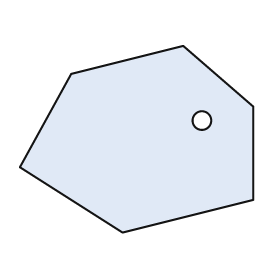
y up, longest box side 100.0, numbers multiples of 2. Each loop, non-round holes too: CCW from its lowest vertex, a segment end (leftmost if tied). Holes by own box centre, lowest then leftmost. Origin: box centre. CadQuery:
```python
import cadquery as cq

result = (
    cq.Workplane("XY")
    .moveTo(-6.0, -40.0)
    .lineTo(50.0, -26.0)
    .lineTo(50.0, 14.0)
    .lineTo(20.0, 40.0)
    .lineTo(-28.0, 28.0)
    .lineTo(-50.0, -12.0)
    .close()
    .moveTo(28.0, 8.0)
    .circle(4.0)
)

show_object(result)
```